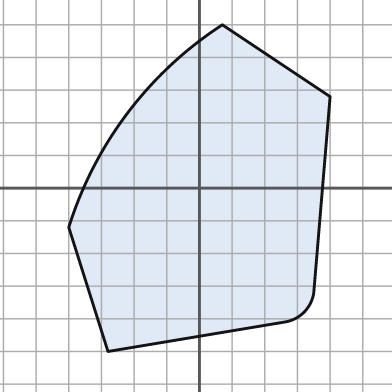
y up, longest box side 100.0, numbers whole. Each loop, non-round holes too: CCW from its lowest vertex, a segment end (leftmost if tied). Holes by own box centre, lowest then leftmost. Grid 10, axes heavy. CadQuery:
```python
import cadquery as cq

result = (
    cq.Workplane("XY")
    .moveTo(-28.0, -50.0)
    .lineTo(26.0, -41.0)
    .threePointArc((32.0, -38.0), (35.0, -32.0))
    .lineTo(40.0, 28.0)
    .lineTo(7.0, 50.0)
    .threePointArc((-22.0, 23.0), (-40.0, -12.0))
    .close()
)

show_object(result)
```